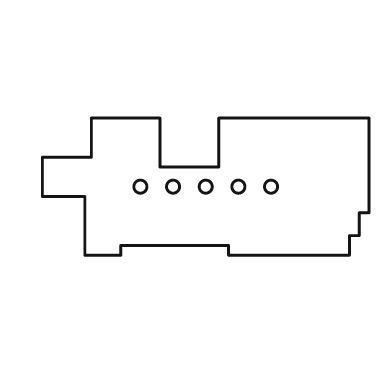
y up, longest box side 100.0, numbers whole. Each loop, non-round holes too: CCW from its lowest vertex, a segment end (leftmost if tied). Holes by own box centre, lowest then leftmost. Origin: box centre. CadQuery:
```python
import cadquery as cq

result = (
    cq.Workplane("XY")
    .moveTo(-37.0, -21.0)
    .lineTo(-26.0, -21.0)
    .lineTo(-26.0, -18.0)
    .lineTo(7.0, -18.0)
    .lineTo(7.0, -21.0)
    .lineTo(44.0, -21.0)
    .lineTo(44.0, -15.0)
    .lineTo(47.0, -15.0)
    .lineTo(47.0, -8.0)
    .lineTo(50.0, -8.0)
    .lineTo(50.0, 21.0)
    .lineTo(4.0, 21.0)
    .lineTo(4.0, 6.0)
    .lineTo(-14.0, 6.0)
    .lineTo(-14.0, 21.0)
    .lineTo(-35.0, 21.0)
    .lineTo(-35.0, 9.0)
    .lineTo(-50.0, 9.0)
    .lineTo(-50.0, -3.0)
    .lineTo(-37.0, -3.0)
    .close()
    .moveTo(-20.0, 0.0)
    .circle(2.0)
    .moveTo(-10.0, 0.0)
    .circle(2.0)
    .moveTo(0.0, 0.0)
    .circle(2.0)
    .moveTo(10.0, 0.0)
    .circle(2.0)
    .moveTo(20.0, 0.0)
    .circle(2.0)
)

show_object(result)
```